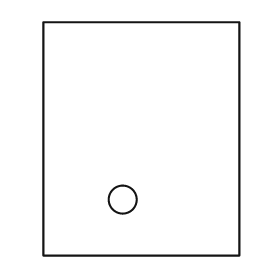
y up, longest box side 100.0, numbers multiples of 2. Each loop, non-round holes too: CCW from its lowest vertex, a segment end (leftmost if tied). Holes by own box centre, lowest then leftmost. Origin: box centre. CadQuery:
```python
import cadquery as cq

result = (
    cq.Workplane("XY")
    .moveTo(-42.0, -50.0)
    .lineTo(42.0, -50.0)
    .lineTo(42.0, 50.0)
    .lineTo(-42.0, 50.0)
    .close()
    .moveTo(-8.0, -26.0)
    .circle(6.0)
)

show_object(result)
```